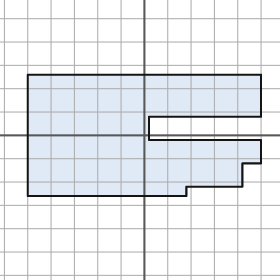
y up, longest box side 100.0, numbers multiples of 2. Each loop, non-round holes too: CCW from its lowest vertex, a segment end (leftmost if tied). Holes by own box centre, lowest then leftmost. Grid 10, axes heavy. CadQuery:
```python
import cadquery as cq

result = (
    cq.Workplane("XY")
    .moveTo(-50.0, -26.0)
    .lineTo(18.0, -26.0)
    .lineTo(18.0, -22.0)
    .lineTo(42.0, -22.0)
    .lineTo(42.0, -12.0)
    .lineTo(50.0, -12.0)
    .lineTo(50.0, -2.0)
    .lineTo(2.0, -2.0)
    .lineTo(2.0, 8.0)
    .lineTo(50.0, 8.0)
    .lineTo(50.0, 26.0)
    .lineTo(-50.0, 26.0)
    .close()
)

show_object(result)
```